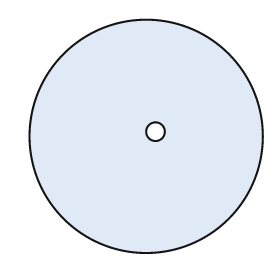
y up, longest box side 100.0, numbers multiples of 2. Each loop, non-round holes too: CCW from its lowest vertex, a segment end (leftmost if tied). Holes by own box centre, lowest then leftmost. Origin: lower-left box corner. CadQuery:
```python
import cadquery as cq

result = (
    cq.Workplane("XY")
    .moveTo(50.0, 50.0)
    .circle(50.0)
    .moveTo(54.0, 52.0)
    .circle(4.0)
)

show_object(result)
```